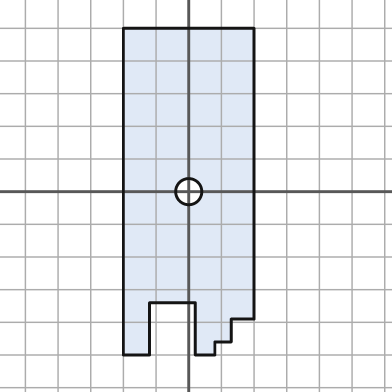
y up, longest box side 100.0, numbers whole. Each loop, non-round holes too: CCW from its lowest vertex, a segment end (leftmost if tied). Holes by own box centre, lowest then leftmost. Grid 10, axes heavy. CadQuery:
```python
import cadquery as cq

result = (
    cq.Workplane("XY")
    .moveTo(-20.0, -50.0)
    .lineTo(-12.0, -50.0)
    .lineTo(-12.0, -34.0)
    .lineTo(2.0, -34.0)
    .lineTo(2.0, -50.0)
    .lineTo(8.0, -50.0)
    .lineTo(8.0, -46.0)
    .lineTo(13.0, -46.0)
    .lineTo(13.0, -39.0)
    .lineTo(20.0, -39.0)
    .lineTo(20.0, 50.0)
    .lineTo(-20.0, 50.0)
    .close()
    .moveTo(0.0, 0.0)
    .circle(4.0)
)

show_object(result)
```